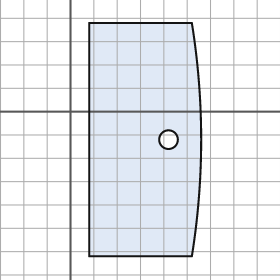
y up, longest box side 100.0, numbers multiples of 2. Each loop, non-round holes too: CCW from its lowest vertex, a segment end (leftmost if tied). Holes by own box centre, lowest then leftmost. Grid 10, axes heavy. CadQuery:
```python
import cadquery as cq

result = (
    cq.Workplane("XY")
    .moveTo(8.0, -62.0)
    .lineTo(52.0, -62.0)
    .threePointArc((56.0, -12.0), (52.0, 38.0))
    .lineTo(8.0, 38.0)
    .close()
    .moveTo(42.0, -12.0)
    .circle(4.0)
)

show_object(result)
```